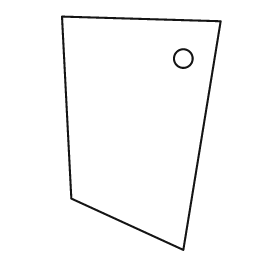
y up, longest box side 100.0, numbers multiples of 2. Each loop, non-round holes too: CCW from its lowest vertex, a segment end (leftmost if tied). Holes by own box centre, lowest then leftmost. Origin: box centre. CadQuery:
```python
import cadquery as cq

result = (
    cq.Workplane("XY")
    .moveTo(18.0, -50.0)
    .lineTo(34.0, 48.0)
    .lineTo(-34.0, 50.0)
    .lineTo(-30.0, -28.0)
    .close()
    .moveTo(18.0, 32.0)
    .circle(4.0)
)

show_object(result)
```